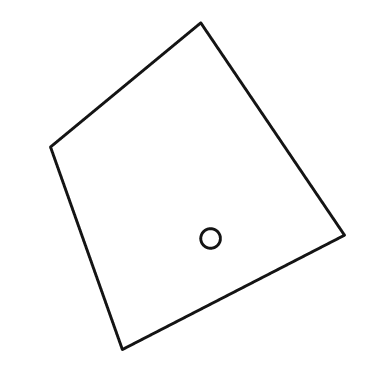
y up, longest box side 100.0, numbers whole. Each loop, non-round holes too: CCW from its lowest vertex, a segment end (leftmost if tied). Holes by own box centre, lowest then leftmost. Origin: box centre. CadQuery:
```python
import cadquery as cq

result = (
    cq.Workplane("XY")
    .moveTo(-23.0, -50.0)
    .lineTo(45.0, -15.0)
    .lineTo(1.0, 50.0)
    .lineTo(-45.0, 12.0)
    .close()
    .moveTo(4.0, -16.0)
    .circle(3.0)
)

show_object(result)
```